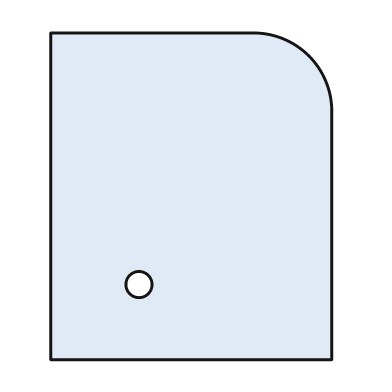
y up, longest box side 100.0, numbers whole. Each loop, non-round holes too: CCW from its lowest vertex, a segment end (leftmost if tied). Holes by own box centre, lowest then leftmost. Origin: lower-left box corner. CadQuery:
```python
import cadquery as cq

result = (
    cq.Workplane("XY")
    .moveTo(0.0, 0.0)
    .lineTo(86.0, 0.0)
    .lineTo(86.0, 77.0)
    .threePointArc((79.0, 93.0), (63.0, 100.0))
    .lineTo(0.0, 100.0)
    .close()
    .moveTo(27.0, 23.0)
    .circle(4.0)
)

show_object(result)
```